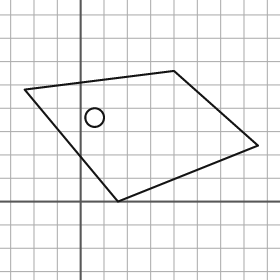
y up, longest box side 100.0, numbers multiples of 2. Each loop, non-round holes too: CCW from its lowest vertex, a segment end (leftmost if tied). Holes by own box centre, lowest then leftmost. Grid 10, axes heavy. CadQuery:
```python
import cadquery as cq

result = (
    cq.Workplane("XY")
    .moveTo(16.0, 0.0)
    .lineTo(76.0, 24.0)
    .lineTo(40.0, 56.0)
    .lineTo(-24.0, 48.0)
    .close()
    .moveTo(6.0, 36.0)
    .circle(4.0)
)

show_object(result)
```